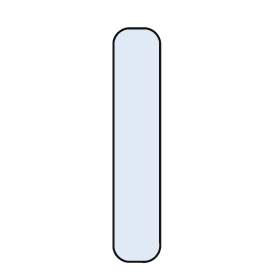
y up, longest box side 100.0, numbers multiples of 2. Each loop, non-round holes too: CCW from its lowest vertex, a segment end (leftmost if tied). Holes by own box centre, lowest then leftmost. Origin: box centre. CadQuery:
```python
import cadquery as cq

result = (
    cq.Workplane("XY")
    .moveTo(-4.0, -50.0)
    .lineTo(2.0, -50.0)
    .threePointArc((8.0, -48.0), (10.0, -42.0))
    .lineTo(10.0, 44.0)
    .threePointArc((8.0, 48.0), (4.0, 50.0))
    .lineTo(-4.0, 50.0)
    .threePointArc((-8.0, 48.0), (-10.0, 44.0))
    .lineTo(-10.0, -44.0)
    .threePointArc((-8.0, -48.0), (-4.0, -50.0))
    .close()
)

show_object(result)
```